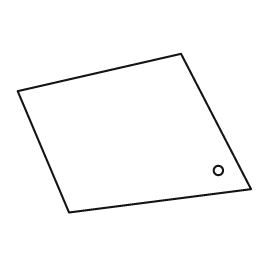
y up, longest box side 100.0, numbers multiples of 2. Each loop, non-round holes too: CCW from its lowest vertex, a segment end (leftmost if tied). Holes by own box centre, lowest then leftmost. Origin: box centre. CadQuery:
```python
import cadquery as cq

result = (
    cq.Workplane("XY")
    .moveTo(-28.0, -34.0)
    .lineTo(50.0, -24.0)
    .lineTo(20.0, 34.0)
    .lineTo(-50.0, 18.0)
    .close()
    .moveTo(36.0, -16.0)
    .circle(2.0)
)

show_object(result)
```